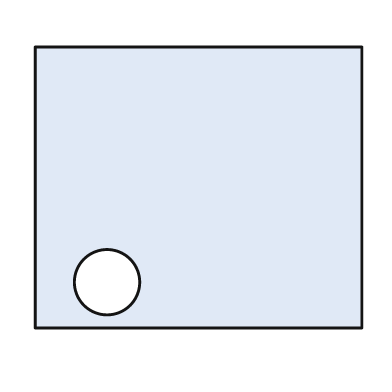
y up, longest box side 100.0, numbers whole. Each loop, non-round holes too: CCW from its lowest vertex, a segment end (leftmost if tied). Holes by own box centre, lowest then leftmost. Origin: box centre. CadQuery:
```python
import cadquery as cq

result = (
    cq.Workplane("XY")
    .moveTo(-50.0, -43.0)
    .lineTo(50.0, -43.0)
    .lineTo(50.0, 43.0)
    .lineTo(-50.0, 43.0)
    .close()
    .moveTo(-28.0, -29.0)
    .circle(10.0)
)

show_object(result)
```